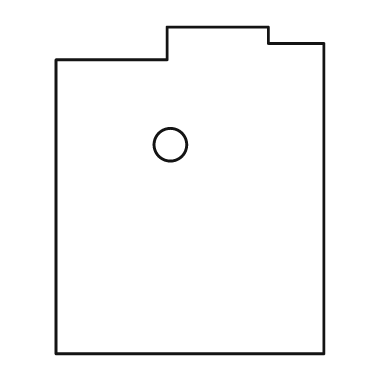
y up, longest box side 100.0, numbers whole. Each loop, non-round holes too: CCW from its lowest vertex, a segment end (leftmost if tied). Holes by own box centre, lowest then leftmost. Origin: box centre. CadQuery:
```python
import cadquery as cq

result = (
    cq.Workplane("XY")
    .moveTo(-41.0, -50.0)
    .lineTo(41.0, -50.0)
    .lineTo(41.0, 45.0)
    .lineTo(24.0, 45.0)
    .lineTo(24.0, 50.0)
    .lineTo(-7.0, 50.0)
    .lineTo(-7.0, 40.0)
    .lineTo(-41.0, 40.0)
    .close()
    .moveTo(-6.0, 14.0)
    .circle(5.0)
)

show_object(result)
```